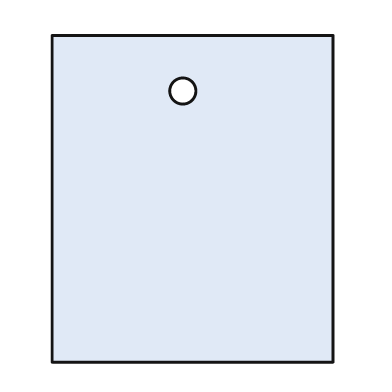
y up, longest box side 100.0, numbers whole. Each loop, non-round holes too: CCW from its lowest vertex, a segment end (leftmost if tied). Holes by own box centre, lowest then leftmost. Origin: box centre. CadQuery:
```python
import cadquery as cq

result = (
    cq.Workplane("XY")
    .moveTo(-43.0, -50.0)
    .lineTo(43.0, -50.0)
    .lineTo(43.0, 50.0)
    .lineTo(-43.0, 50.0)
    .close()
    .moveTo(-3.0, 33.0)
    .circle(4.0)
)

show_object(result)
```